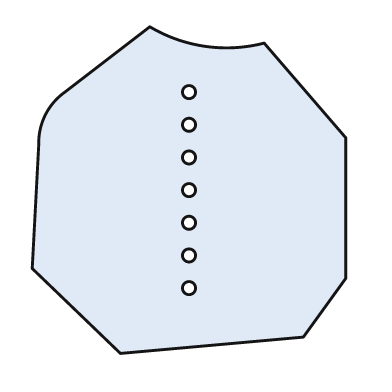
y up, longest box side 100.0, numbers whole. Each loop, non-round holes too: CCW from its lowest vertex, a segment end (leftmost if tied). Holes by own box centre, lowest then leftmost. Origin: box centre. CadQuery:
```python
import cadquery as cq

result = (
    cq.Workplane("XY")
    .moveTo(-21.0, -50.0)
    .lineTo(35.0, -45.0)
    .lineTo(48.0, -27.0)
    .lineTo(48.0, 16.0)
    .lineTo(23.0, 45.0)
    .threePointArc((5.0, 44.0), (-12.0, 50.0))
    .lineTo(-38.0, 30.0)
    .threePointArc((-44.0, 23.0), (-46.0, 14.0))
    .lineTo(-48.0, -24.0)
    .close()
    .moveTo(0.0, -30.0)
    .circle(2.0)
    .moveTo(0.0, -20.0)
    .circle(2.0)
    .moveTo(0.0, -10.0)
    .circle(2.0)
    .moveTo(0.0, 0.0)
    .circle(2.0)
    .moveTo(0.0, 10.0)
    .circle(2.0)
    .moveTo(0.0, 20.0)
    .circle(2.0)
    .moveTo(0.0, 30.0)
    .circle(2.0)
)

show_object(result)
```